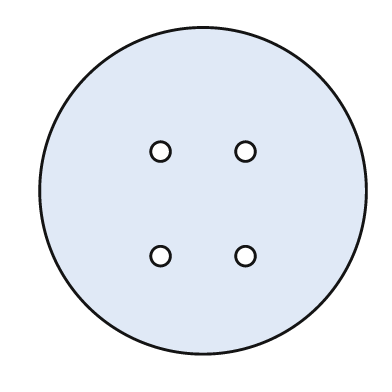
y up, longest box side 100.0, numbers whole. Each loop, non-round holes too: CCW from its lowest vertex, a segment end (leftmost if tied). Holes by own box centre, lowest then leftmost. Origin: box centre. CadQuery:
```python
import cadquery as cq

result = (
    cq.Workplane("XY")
    .moveTo(0.0, 0.0)
    .circle(50.0)
    .moveTo(-13.0, -20.0)
    .circle(3.0)
    .moveTo(13.0, -20.0)
    .circle(3.0)
    .moveTo(-13.0, 12.0)
    .circle(3.0)
    .moveTo(13.0, 12.0)
    .circle(3.0)
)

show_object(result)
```